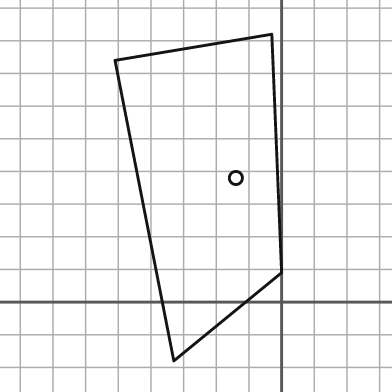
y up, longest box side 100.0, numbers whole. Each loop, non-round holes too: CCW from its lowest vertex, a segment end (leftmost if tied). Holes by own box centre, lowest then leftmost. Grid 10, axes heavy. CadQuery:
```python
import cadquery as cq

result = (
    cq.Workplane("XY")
    .moveTo(-33.0, -18.0)
    .lineTo(0.0, 9.0)
    .lineTo(-3.0, 82.0)
    .lineTo(-51.0, 74.0)
    .close()
    .moveTo(-14.0, 38.0)
    .circle(2.0)
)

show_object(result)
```